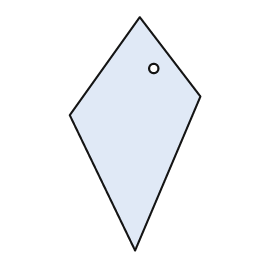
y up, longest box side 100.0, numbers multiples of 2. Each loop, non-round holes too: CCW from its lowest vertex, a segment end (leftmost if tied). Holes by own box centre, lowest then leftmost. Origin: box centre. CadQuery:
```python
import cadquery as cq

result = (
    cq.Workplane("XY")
    .moveTo(0.0, -50.0)
    .lineTo(28.0, 16.0)
    .lineTo(2.0, 50.0)
    .lineTo(-28.0, 8.0)
    .close()
    .moveTo(8.0, 28.0)
    .circle(2.0)
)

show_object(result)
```